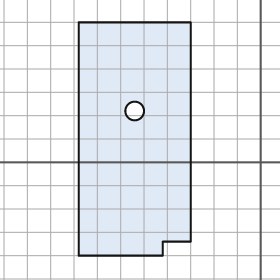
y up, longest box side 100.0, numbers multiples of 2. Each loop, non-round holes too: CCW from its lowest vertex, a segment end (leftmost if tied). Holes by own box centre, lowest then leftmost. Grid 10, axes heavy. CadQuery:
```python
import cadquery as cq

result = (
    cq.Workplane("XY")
    .moveTo(-78.0, -40.0)
    .lineTo(-42.0, -40.0)
    .lineTo(-42.0, -34.0)
    .lineTo(-30.0, -34.0)
    .lineTo(-30.0, 60.0)
    .lineTo(-78.0, 60.0)
    .close()
    .moveTo(-54.0, 22.0)
    .circle(4.0)
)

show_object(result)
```